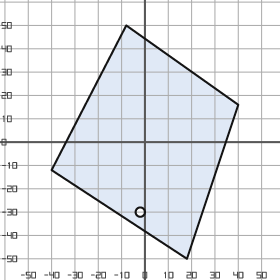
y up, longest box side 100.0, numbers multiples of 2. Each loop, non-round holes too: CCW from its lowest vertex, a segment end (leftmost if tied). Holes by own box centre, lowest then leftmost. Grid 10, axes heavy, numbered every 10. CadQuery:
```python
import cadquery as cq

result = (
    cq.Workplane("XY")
    .moveTo(18.0, -50.0)
    .lineTo(40.0, 16.0)
    .lineTo(-8.0, 50.0)
    .lineTo(-40.0, -12.0)
    .close()
    .moveTo(-2.0, -30.0)
    .circle(2.0)
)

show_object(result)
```